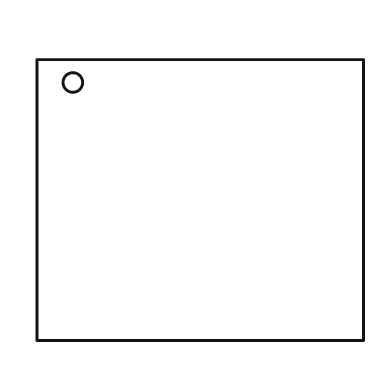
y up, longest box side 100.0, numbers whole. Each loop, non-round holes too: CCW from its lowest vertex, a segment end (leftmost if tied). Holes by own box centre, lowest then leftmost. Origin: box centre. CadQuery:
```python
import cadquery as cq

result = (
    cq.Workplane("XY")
    .moveTo(-50.0, -43.0)
    .lineTo(50.0, -43.0)
    .lineTo(50.0, 43.0)
    .lineTo(-50.0, 43.0)
    .close()
    .moveTo(-39.0, 36.0)
    .circle(3.0)
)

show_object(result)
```